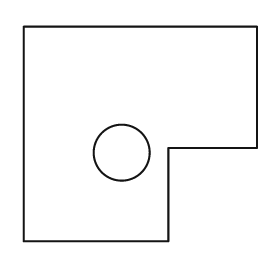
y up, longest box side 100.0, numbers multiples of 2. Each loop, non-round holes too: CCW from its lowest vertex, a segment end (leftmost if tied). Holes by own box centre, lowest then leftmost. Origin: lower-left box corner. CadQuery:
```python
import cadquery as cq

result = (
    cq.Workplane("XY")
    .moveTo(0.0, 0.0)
    .lineTo(62.0, 0.0)
    .lineTo(62.0, 40.0)
    .lineTo(100.0, 40.0)
    .lineTo(100.0, 92.0)
    .lineTo(0.0, 92.0)
    .close()
    .moveTo(42.0, 38.0)
    .circle(12.0)
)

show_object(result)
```